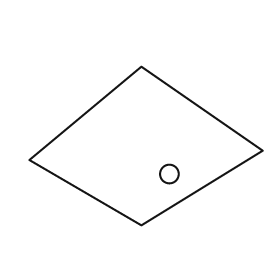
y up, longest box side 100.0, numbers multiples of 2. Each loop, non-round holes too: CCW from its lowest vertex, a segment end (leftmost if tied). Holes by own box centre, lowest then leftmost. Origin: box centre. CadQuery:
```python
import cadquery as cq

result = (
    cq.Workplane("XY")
    .moveTo(-2.0, -34.0)
    .lineTo(50.0, -2.0)
    .lineTo(-2.0, 34.0)
    .lineTo(-50.0, -6.0)
    .close()
    .moveTo(10.0, -12.0)
    .circle(4.0)
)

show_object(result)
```